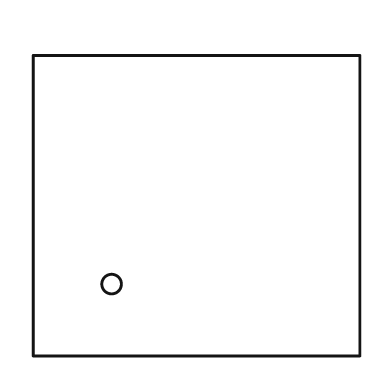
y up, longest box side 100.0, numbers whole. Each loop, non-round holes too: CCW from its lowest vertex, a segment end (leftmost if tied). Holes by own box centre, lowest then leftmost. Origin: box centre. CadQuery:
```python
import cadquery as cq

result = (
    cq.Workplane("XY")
    .moveTo(-50.0, -46.0)
    .lineTo(50.0, -46.0)
    .lineTo(50.0, 46.0)
    .lineTo(-50.0, 46.0)
    .close()
    .moveTo(-26.0, -24.0)
    .circle(3.0)
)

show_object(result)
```